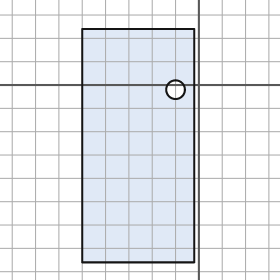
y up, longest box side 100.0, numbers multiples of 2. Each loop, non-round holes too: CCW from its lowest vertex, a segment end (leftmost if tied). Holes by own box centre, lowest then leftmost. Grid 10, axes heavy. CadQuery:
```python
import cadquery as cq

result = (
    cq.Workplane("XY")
    .moveTo(-50.0, -76.0)
    .lineTo(-2.0, -76.0)
    .lineTo(-2.0, 24.0)
    .lineTo(-50.0, 24.0)
    .close()
    .moveTo(-10.0, -2.0)
    .circle(4.0)
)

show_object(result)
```